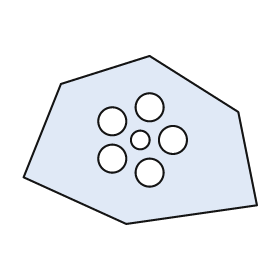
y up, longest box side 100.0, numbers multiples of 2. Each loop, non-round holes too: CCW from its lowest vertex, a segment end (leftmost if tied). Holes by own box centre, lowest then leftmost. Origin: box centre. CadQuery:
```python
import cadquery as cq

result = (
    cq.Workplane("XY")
    .moveTo(-6.0, -36.0)
    .lineTo(50.0, -28.0)
    .lineTo(42.0, 12.0)
    .lineTo(4.0, 36.0)
    .lineTo(-34.0, 24.0)
    .lineTo(-50.0, -16.0)
    .close()
    .moveTo(4.0, -14.0)
    .circle(6.0)
    .moveTo(-12.0, -8.0)
    .circle(6.0)
    .moveTo(0.0, 0.0)
    .circle(4.0)
    .moveTo(14.0, 0.0)
    .circle(6.0)
    .moveTo(-12.0, 8.0)
    .circle(6.0)
    .moveTo(4.0, 14.0)
    .circle(6.0)
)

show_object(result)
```